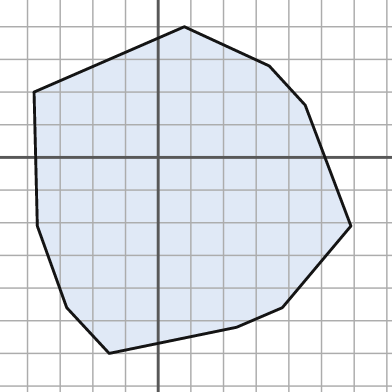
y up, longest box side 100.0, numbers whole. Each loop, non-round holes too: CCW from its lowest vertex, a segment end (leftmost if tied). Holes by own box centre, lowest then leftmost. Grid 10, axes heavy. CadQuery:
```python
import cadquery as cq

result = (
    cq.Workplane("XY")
    .moveTo(-15.0, -60.0)
    .lineTo(24.0, -52.0)
    .lineTo(38.0, -46.0)
    .lineTo(59.0, -21.0)
    .lineTo(45.0, 16.0)
    .lineTo(34.0, 28.0)
    .lineTo(8.0, 40.0)
    .lineTo(-38.0, 20.0)
    .lineTo(-37.0, -21.0)
    .lineTo(-28.0, -46.0)
    .close()
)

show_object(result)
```